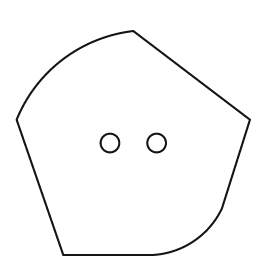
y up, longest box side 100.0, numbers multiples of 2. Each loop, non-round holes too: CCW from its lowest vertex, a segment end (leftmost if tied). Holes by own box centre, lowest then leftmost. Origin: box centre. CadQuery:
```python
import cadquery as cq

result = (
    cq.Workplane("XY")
    .moveTo(-30.0, -48.0)
    .lineTo(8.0, -48.0)
    .threePointArc((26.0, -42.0), (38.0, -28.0))
    .lineTo(50.0, 10.0)
    .lineTo(0.0, 48.0)
    .threePointArc((-30.0, 36.0), (-50.0, 10.0))
    .close()
    .moveTo(-10.0, 0.0)
    .circle(4.0)
    .moveTo(10.0, 0.0)
    .circle(4.0)
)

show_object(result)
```